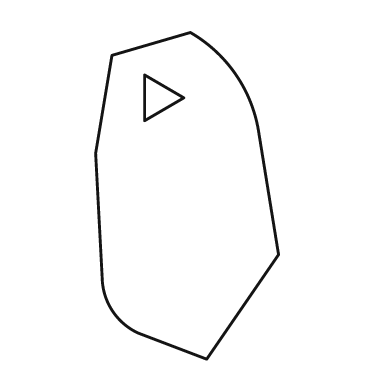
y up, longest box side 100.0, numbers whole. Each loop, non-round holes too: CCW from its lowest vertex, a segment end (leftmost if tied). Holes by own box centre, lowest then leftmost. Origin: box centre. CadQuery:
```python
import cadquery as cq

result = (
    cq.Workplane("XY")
    .moveTo(6.0, -50.0)
    .lineTo(28.0, -18.0)
    .lineTo(22.0, 19.0)
    .threePointArc((15.0, 37.0), (1.0, 50.0))
    .lineTo(-23.0, 43.0)
    .lineTo(-28.0, 13.0)
    .lineTo(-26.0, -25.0)
    .threePointArc((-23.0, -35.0), (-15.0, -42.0))
    .close()
    .moveTo(-13.0, 23.0)
    .lineTo(-1.0, 30.0)
    .lineTo(-13.0, 37.0)
    .close()
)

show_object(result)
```